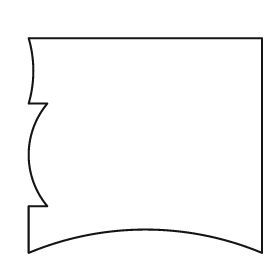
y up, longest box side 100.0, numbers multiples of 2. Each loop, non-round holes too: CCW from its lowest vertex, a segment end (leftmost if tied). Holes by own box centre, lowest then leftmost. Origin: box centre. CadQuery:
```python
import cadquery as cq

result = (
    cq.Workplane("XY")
    .moveTo(-50.0, -46.0)
    .threePointArc((0.0, -36.0), (50.0, -46.0))
    .lineTo(50.0, 46.0)
    .lineTo(-50.0, 46.0)
    .threePointArc((-48.0, 32.0), (-50.0, 18.0))
    .lineTo(-42.0, 18.0)
    .threePointArc((-50.0, -4.0), (-42.0, -26.0))
    .lineTo(-50.0, -26.0)
    .close()
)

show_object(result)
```